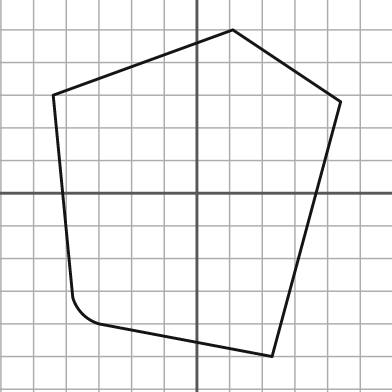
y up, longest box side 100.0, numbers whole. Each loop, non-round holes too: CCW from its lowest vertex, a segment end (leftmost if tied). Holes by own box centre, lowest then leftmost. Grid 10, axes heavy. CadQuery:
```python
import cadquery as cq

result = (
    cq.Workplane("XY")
    .moveTo(23.0, -50.0)
    .lineTo(44.0, 28.0)
    .lineTo(11.0, 50.0)
    .lineTo(-44.0, 30.0)
    .lineTo(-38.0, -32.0)
    .threePointArc((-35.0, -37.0), (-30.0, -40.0))
    .close()
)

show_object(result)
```